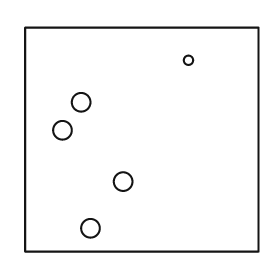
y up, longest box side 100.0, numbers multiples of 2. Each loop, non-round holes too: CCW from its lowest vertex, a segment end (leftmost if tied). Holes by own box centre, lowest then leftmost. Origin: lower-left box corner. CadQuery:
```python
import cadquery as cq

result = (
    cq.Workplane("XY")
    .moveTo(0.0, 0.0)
    .lineTo(100.0, 0.0)
    .lineTo(100.0, 96.0)
    .lineTo(0.0, 96.0)
    .close()
    .moveTo(28.0, 10.0)
    .circle(4.0)
    .moveTo(42.0, 30.0)
    .circle(4.0)
    .moveTo(16.0, 52.0)
    .circle(4.0)
    .moveTo(24.0, 64.0)
    .circle(4.0)
    .moveTo(70.0, 82.0)
    .circle(2.0)
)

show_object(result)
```